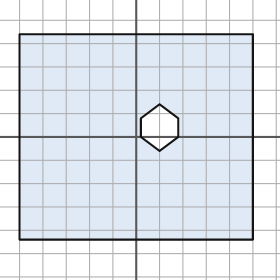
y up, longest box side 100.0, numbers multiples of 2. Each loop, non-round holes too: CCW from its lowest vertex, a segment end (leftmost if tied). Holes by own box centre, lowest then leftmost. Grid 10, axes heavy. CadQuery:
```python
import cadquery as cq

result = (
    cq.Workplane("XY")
    .moveTo(-50.0, -44.0)
    .lineTo(50.0, -44.0)
    .lineTo(50.0, 44.0)
    .lineTo(-50.0, 44.0)
    .close()
    .moveTo(10.0, -6.0)
    .lineTo(18.0, 0.0)
    .lineTo(18.0, 8.0)
    .lineTo(10.0, 14.0)
    .lineTo(2.0, 8.0)
    .lineTo(2.0, 0.0)
    .close()
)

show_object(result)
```